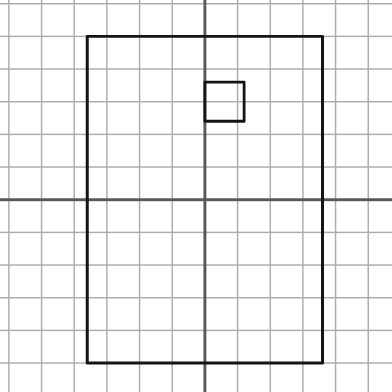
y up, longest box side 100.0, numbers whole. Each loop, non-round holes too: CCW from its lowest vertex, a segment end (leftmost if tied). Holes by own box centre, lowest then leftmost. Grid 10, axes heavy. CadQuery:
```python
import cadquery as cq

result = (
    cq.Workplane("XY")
    .moveTo(-36.0, -50.0)
    .lineTo(36.0, -50.0)
    .lineTo(36.0, 50.0)
    .lineTo(-36.0, 50.0)
    .close()
    .moveTo(0.0, 24.0)
    .lineTo(12.0, 24.0)
    .lineTo(12.0, 36.0)
    .lineTo(0.0, 36.0)
    .close()
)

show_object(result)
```